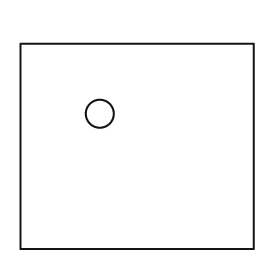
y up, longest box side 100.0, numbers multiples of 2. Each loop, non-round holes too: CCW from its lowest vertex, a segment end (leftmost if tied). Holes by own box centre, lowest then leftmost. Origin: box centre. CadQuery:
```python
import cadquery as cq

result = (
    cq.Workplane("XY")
    .moveTo(-50.0, -44.0)
    .lineTo(50.0, -44.0)
    .lineTo(50.0, 44.0)
    .lineTo(-50.0, 44.0)
    .close()
    .moveTo(-16.0, 14.0)
    .circle(6.0)
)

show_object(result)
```